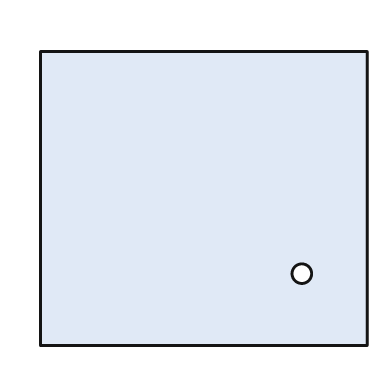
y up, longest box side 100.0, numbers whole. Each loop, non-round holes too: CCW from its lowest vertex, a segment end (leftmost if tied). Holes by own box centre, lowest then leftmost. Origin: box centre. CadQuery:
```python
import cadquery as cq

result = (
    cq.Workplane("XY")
    .moveTo(-50.0, -45.0)
    .lineTo(50.0, -45.0)
    .lineTo(50.0, 45.0)
    .lineTo(-50.0, 45.0)
    .close()
    .moveTo(30.0, -23.0)
    .circle(3.0)
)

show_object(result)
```